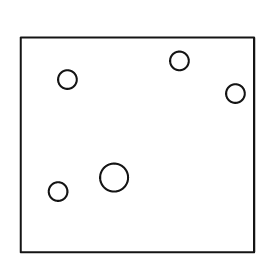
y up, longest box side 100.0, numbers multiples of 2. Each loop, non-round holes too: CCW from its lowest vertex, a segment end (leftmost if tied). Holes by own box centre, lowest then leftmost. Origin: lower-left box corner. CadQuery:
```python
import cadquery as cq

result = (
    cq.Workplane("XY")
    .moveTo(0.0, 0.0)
    .lineTo(100.0, 0.0)
    .lineTo(100.0, 92.0)
    .lineTo(0.0, 92.0)
    .close()
    .moveTo(16.0, 26.0)
    .circle(4.0)
    .moveTo(40.0, 32.0)
    .circle(6.0)
    .moveTo(92.0, 68.0)
    .circle(4.0)
    .moveTo(20.0, 74.0)
    .circle(4.0)
    .moveTo(68.0, 82.0)
    .circle(4.0)
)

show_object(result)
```